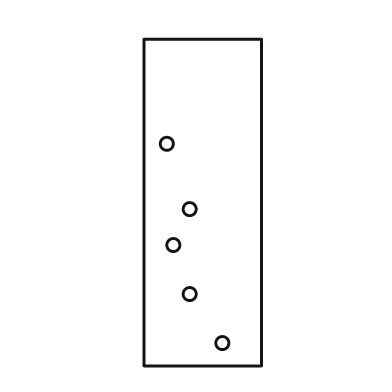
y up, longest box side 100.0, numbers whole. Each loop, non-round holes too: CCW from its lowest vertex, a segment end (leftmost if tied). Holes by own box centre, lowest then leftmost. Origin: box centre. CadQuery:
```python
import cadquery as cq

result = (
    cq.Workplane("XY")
    .moveTo(-18.0, -50.0)
    .lineTo(18.0, -50.0)
    .lineTo(18.0, 50.0)
    .lineTo(-18.0, 50.0)
    .close()
    .moveTo(6.0, -43.0)
    .circle(2.0)
    .moveTo(-4.0, -28.0)
    .circle(2.0)
    .moveTo(-9.0, -13.0)
    .circle(2.0)
    .moveTo(-4.0, -2.0)
    .circle(2.0)
    .moveTo(-11.0, 18.0)
    .circle(2.0)
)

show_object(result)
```